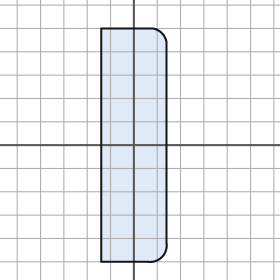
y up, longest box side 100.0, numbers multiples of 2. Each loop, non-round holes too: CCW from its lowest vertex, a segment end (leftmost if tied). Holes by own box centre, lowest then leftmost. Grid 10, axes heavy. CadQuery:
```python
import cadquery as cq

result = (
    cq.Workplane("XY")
    .moveTo(-14.0, -50.0)
    .lineTo(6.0, -50.0)
    .threePointArc((12.0, -48.0), (14.0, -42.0))
    .lineTo(14.0, 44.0)
    .threePointArc((12.0, 48.0), (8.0, 50.0))
    .lineTo(-14.0, 50.0)
    .close()
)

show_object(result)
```